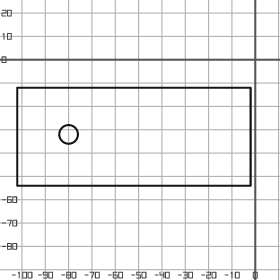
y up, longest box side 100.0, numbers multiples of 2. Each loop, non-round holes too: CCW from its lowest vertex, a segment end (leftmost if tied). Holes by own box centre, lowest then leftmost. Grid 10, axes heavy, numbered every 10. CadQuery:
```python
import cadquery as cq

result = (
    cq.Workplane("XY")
    .moveTo(-102.0, -54.0)
    .lineTo(-2.0, -54.0)
    .lineTo(-2.0, -12.0)
    .lineTo(-102.0, -12.0)
    .close()
    .moveTo(-80.0, -32.0)
    .circle(4.0)
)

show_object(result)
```